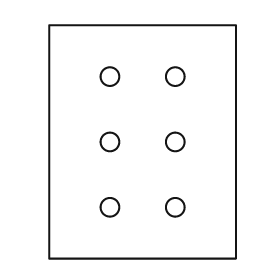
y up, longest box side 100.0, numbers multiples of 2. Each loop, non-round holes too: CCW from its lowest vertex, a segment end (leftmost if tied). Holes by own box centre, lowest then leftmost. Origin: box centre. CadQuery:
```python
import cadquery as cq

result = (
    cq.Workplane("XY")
    .moveTo(-40.0, -50.0)
    .lineTo(40.0, -50.0)
    .lineTo(40.0, 50.0)
    .lineTo(-40.0, 50.0)
    .close()
    .moveTo(-14.0, -28.0)
    .circle(4.0)
    .moveTo(14.0, -28.0)
    .circle(4.0)
    .moveTo(-14.0, 0.0)
    .circle(4.0)
    .moveTo(14.0, 0.0)
    .circle(4.0)
    .moveTo(-14.0, 28.0)
    .circle(4.0)
    .moveTo(14.0, 28.0)
    .circle(4.0)
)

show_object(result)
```